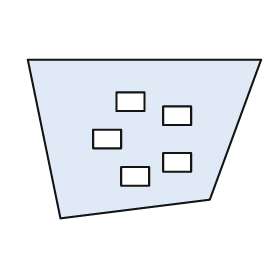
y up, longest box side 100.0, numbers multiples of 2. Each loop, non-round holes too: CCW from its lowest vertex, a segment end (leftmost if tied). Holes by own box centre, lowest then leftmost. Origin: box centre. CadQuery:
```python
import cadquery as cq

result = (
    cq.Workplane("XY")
    .moveTo(-36.0, -34.0)
    .lineTo(28.0, -26.0)
    .lineTo(50.0, 34.0)
    .lineTo(-50.0, 34.0)
    .close()
    .moveTo(-10.0, -20.0)
    .lineTo(2.0, -20.0)
    .lineTo(2.0, -12.0)
    .lineTo(-10.0, -12.0)
    .close()
    .moveTo(8.0, -14.0)
    .lineTo(20.0, -14.0)
    .lineTo(20.0, -6.0)
    .lineTo(8.0, -6.0)
    .close()
    .moveTo(-22.0, -4.0)
    .lineTo(-10.0, -4.0)
    .lineTo(-10.0, 4.0)
    .lineTo(-22.0, 4.0)
    .close()
    .moveTo(8.0, 6.0)
    .lineTo(20.0, 6.0)
    .lineTo(20.0, 14.0)
    .lineTo(8.0, 14.0)
    .close()
    .moveTo(-12.0, 12.0)
    .lineTo(0.0, 12.0)
    .lineTo(0.0, 20.0)
    .lineTo(-12.0, 20.0)
    .close()
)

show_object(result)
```